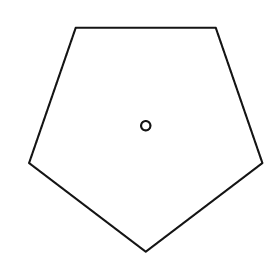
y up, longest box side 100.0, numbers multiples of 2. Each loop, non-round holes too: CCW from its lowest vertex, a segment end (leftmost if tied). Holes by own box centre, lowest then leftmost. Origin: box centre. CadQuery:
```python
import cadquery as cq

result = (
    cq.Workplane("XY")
    .moveTo(0.0, -48.0)
    .lineTo(50.0, -10.0)
    .lineTo(30.0, 48.0)
    .lineTo(-30.0, 48.0)
    .lineTo(-50.0, -10.0)
    .close()
    .moveTo(0.0, 6.0)
    .circle(2.0)
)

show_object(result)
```